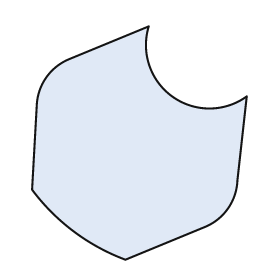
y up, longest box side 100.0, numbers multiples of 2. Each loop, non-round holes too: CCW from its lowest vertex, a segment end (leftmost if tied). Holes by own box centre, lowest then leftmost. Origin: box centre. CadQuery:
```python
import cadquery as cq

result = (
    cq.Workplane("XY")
    .moveTo(-6.0, -50.0)
    .lineTo(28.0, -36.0)
    .threePointArc((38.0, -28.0), (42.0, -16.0))
    .lineTo(46.0, 20.0)
    .threePointArc((14.0, 20.0), (4.0, 50.0))
    .lineTo(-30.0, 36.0)
    .threePointArc((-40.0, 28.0), (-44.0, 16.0))
    .lineTo(-46.0, -20.0)
    .threePointArc((-28.0, -38.0), (-6.0, -50.0))
    .close()
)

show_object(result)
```